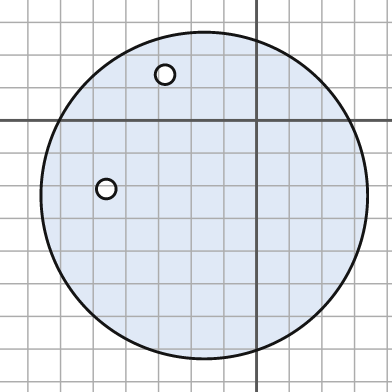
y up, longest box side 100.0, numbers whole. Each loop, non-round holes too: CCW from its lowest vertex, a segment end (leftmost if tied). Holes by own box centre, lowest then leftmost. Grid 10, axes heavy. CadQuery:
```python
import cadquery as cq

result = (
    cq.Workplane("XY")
    .moveTo(-16.0, -23.0)
    .circle(50.0)
    .moveTo(-46.0, -21.0)
    .circle(3.0)
    .moveTo(-28.0, 14.0)
    .circle(3.0)
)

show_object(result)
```